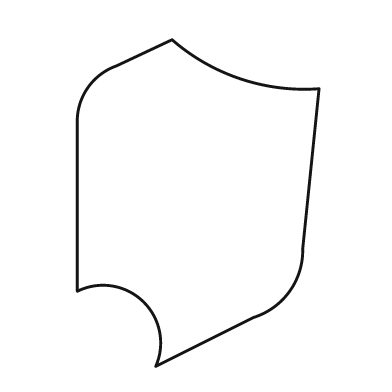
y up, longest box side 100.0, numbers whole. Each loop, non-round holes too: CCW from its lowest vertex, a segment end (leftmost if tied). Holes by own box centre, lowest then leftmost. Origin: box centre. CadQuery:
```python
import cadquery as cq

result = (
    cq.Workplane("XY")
    .moveTo(-13.0, -50.0)
    .lineTo(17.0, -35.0)
    .threePointArc((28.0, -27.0), (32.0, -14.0))
    .lineTo(37.0, 35.0)
    .threePointArc((13.0, 38.0), (-8.0, 50.0))
    .lineTo(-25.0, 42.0)
    .threePointArc((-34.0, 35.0), (-37.0, 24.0))
    .lineTo(-37.0, -27.0)
    .threePointArc((-17.0, -30.0), (-13.0, -50.0))
    .close()
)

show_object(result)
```